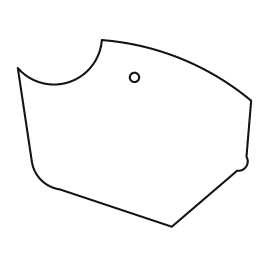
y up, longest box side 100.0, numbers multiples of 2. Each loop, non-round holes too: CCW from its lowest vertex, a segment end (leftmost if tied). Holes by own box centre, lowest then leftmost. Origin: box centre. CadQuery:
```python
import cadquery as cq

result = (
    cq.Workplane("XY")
    .moveTo(16.0, -40.0)
    .lineTo(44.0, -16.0)
    .threePointArc((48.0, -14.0), (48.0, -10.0))
    .lineTo(50.0, 14.0)
    .threePointArc((20.0, 32.0), (-14.0, 40.0))
    .threePointArc((-28.0, 22.0), (-50.0, 28.0))
    .lineTo(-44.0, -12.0)
    .threePointArc((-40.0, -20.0), (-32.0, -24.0))
    .close()
    .moveTo(0.0, 24.0)
    .circle(2.0)
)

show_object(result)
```